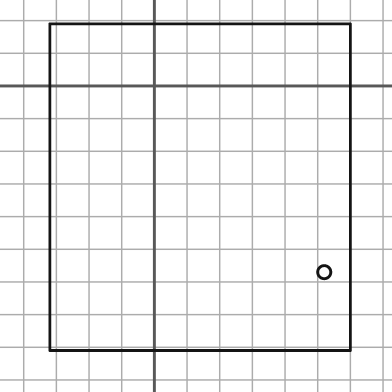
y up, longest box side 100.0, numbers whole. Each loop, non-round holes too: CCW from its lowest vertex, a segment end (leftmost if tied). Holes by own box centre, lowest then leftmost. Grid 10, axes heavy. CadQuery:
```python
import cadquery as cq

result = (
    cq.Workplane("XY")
    .moveTo(-32.0, -81.0)
    .lineTo(60.0, -81.0)
    .lineTo(60.0, 19.0)
    .lineTo(-32.0, 19.0)
    .close()
    .moveTo(52.0, -57.0)
    .circle(2.0)
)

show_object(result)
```